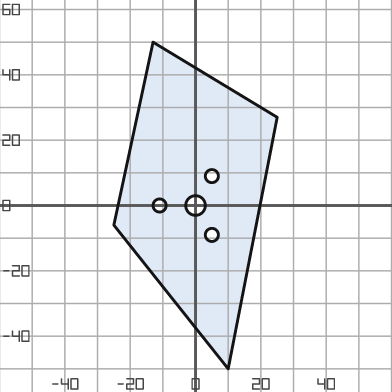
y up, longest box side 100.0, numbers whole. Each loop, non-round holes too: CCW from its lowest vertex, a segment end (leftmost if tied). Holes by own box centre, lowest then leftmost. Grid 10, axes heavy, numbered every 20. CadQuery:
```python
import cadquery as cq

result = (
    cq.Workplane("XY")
    .moveTo(10.0, -50.0)
    .lineTo(25.0, 27.0)
    .lineTo(-13.0, 50.0)
    .lineTo(-25.0, -6.0)
    .close()
    .moveTo(5.0, -9.0)
    .circle(2.0)
    .moveTo(-11.0, 0.0)
    .circle(2.0)
    .moveTo(0.0, 0.0)
    .circle(3.0)
    .moveTo(5.0, 9.0)
    .circle(2.0)
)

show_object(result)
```